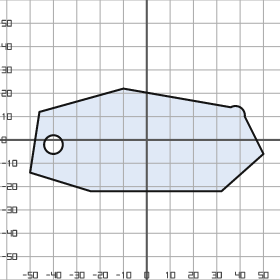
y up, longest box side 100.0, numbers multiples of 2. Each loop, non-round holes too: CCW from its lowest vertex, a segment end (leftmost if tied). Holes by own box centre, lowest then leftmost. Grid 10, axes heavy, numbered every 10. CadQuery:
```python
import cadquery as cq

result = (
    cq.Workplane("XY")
    .moveTo(-24.0, -22.0)
    .lineTo(32.0, -22.0)
    .lineTo(50.0, -6.0)
    .lineTo(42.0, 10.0)
    .threePointArc((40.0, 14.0), (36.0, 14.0))
    .lineTo(-10.0, 22.0)
    .lineTo(-46.0, 12.0)
    .lineTo(-50.0, -14.0)
    .close()
    .moveTo(-40.0, -2.0)
    .circle(4.0)
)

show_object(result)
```